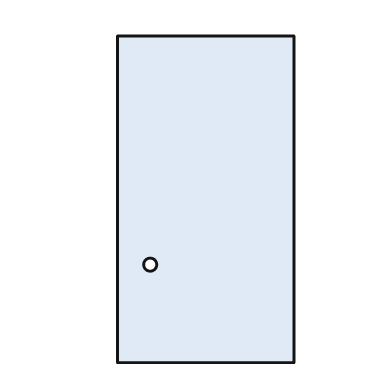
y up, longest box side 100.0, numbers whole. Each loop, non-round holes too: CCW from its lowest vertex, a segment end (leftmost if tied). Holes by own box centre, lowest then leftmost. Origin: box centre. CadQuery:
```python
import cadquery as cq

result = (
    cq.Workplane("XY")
    .moveTo(-27.0, -50.0)
    .lineTo(27.0, -50.0)
    .lineTo(27.0, 50.0)
    .lineTo(-27.0, 50.0)
    .close()
    .moveTo(-17.0, -20.0)
    .circle(2.0)
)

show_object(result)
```